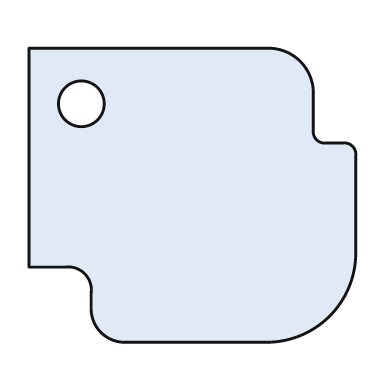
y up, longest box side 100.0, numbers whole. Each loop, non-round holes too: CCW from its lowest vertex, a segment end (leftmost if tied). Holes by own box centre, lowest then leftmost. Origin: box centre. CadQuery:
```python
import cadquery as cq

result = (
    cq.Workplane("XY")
    .moveTo(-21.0, -45.0)
    .lineTo(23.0, -45.0)
    .threePointArc((42.0, -37.0), (50.0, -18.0))
    .lineTo(50.0, 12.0)
    .threePointArc((49.0, 15.0), (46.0, 16.0))
    .lineTo(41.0, 16.0)
    .threePointArc((38.0, 17.0), (37.0, 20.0))
    .lineTo(37.0, 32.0)
    .threePointArc((33.0, 41.0), (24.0, 45.0))
    .lineTo(-50.0, 45.0)
    .lineTo(-50.0, -22.0)
    .lineTo(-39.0, -22.0)
    .threePointArc((-33.0, -24.0), (-31.0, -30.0))
    .lineTo(-31.0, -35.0)
    .threePointArc((-28.0, -42.0), (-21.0, -45.0))
    .close()
    .moveTo(-34.0, 28.0)
    .circle(7.0)
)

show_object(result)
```